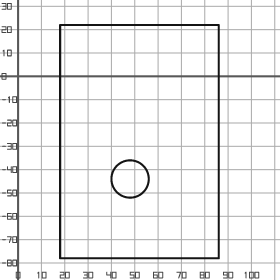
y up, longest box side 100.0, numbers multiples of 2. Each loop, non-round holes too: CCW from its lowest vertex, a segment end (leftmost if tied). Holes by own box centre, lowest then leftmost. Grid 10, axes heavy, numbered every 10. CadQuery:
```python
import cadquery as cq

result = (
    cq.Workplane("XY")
    .moveTo(18.0, -78.0)
    .lineTo(86.0, -78.0)
    .lineTo(86.0, 22.0)
    .lineTo(18.0, 22.0)
    .close()
    .moveTo(48.0, -44.0)
    .circle(8.0)
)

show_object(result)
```